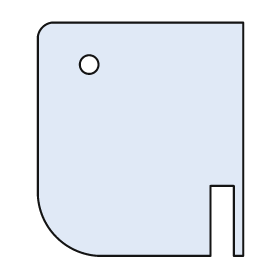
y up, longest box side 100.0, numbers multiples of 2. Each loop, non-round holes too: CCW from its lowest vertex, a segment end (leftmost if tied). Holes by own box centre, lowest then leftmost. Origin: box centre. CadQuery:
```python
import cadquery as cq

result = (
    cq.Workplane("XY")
    .moveTo(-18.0, -50.0)
    .lineTo(30.0, -50.0)
    .lineTo(30.0, -20.0)
    .lineTo(40.0, -20.0)
    .lineTo(40.0, -50.0)
    .lineTo(44.0, -50.0)
    .lineTo(44.0, 50.0)
    .lineTo(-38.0, 50.0)
    .threePointArc((-42.0, 48.0), (-44.0, 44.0))
    .lineTo(-44.0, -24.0)
    .threePointArc((-36.0, -42.0), (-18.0, -50.0))
    .close()
    .moveTo(-22.0, 32.0)
    .circle(4.0)
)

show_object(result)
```